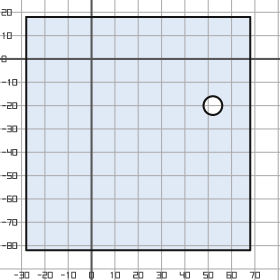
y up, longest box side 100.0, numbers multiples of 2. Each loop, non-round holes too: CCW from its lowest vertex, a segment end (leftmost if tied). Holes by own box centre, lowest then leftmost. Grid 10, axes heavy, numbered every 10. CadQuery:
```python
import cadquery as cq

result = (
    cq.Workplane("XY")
    .moveTo(-28.0, -82.0)
    .lineTo(68.0, -82.0)
    .lineTo(68.0, 18.0)
    .lineTo(-28.0, 18.0)
    .close()
    .moveTo(52.0, -20.0)
    .circle(4.0)
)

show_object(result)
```